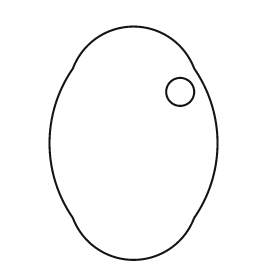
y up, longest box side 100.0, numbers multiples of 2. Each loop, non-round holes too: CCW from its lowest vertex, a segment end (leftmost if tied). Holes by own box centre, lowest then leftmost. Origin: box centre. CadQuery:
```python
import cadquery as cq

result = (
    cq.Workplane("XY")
    .moveTo(-26.0, -32.0)
    .threePointArc((0.0, -50.0), (26.0, -32.0))
    .threePointArc((36.0, 0.0), (26.0, 32.0))
    .threePointArc((0.0, 50.0), (-26.0, 32.0))
    .threePointArc((-36.0, 0.0), (-26.0, -32.0))
    .close()
    .moveTo(20.0, 22.0)
    .circle(6.0)
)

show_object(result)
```